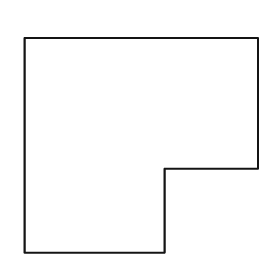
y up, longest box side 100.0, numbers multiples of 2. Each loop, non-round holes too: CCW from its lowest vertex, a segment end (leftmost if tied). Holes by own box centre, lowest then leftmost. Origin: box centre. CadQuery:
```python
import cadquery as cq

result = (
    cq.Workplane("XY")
    .moveTo(-50.0, -46.0)
    .lineTo(10.0, -46.0)
    .lineTo(10.0, -10.0)
    .lineTo(50.0, -10.0)
    .lineTo(50.0, 46.0)
    .lineTo(-50.0, 46.0)
    .close()
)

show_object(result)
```